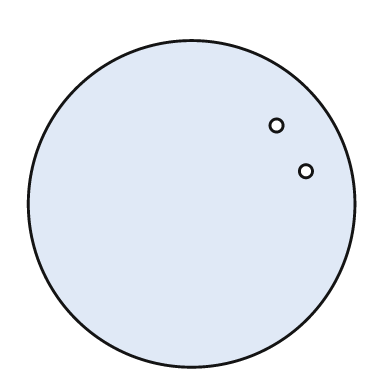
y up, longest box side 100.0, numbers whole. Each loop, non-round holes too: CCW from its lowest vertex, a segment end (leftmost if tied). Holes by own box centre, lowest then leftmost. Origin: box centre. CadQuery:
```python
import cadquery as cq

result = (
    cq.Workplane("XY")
    .moveTo(0.0, 0.0)
    .circle(50.0)
    .moveTo(35.0, 10.0)
    .circle(2.0)
    .moveTo(26.0, 24.0)
    .circle(2.0)
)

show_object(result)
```